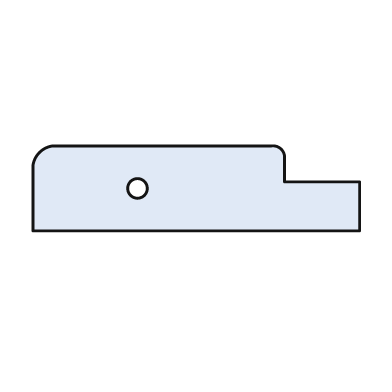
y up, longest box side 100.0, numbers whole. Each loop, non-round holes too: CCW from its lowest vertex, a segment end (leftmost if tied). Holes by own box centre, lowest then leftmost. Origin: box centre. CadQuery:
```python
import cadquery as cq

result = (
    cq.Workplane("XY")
    .moveTo(-50.0, -13.0)
    .lineTo(50.0, -13.0)
    .lineTo(50.0, 2.0)
    .lineTo(27.0, 2.0)
    .lineTo(27.0, 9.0)
    .threePointArc((26.0, 12.0), (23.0, 13.0))
    .lineTo(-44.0, 13.0)
    .threePointArc((-48.0, 11.0), (-50.0, 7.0))
    .close()
    .moveTo(-18.0, 0.0)
    .circle(3.0)
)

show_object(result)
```